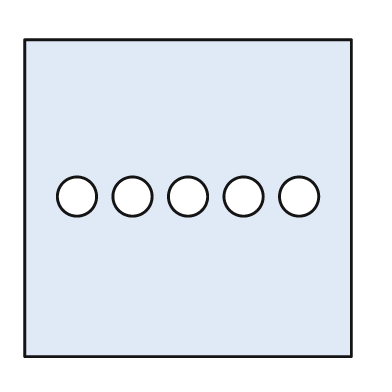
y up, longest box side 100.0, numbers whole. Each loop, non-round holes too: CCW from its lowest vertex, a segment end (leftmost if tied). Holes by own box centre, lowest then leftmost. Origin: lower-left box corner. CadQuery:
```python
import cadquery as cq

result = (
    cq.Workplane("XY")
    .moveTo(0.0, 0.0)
    .lineTo(100.0, 0.0)
    .lineTo(100.0, 97.0)
    .lineTo(0.0, 97.0)
    .close()
    .moveTo(16.0, 49.0)
    .circle(6.0)
    .moveTo(33.0, 49.0)
    .circle(6.0)
    .moveTo(50.0, 49.0)
    .circle(6.0)
    .moveTo(67.0, 49.0)
    .circle(6.0)
    .moveTo(84.0, 49.0)
    .circle(6.0)
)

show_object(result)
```